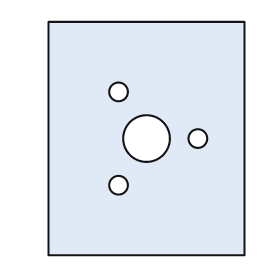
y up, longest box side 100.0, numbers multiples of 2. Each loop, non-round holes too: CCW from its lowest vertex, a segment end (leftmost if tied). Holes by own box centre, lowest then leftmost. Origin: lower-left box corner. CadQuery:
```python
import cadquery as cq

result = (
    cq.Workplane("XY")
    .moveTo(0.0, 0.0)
    .lineTo(84.0, 0.0)
    .lineTo(84.0, 100.0)
    .lineTo(0.0, 100.0)
    .close()
    .moveTo(30.0, 30.0)
    .circle(4.0)
    .moveTo(42.0, 50.0)
    .circle(10.0)
    .moveTo(64.0, 50.0)
    .circle(4.0)
    .moveTo(30.0, 70.0)
    .circle(4.0)
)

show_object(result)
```